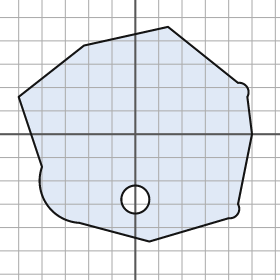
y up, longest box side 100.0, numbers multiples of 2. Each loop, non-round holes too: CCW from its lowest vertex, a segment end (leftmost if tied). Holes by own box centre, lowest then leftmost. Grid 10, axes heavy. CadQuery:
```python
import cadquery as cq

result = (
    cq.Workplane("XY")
    .moveTo(6.0, -46.0)
    .lineTo(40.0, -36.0)
    .threePointArc((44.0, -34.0), (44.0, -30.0))
    .lineTo(50.0, 0.0)
    .lineTo(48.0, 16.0)
    .threePointArc((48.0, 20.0), (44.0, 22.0))
    .lineTo(14.0, 46.0)
    .lineTo(-22.0, 38.0)
    .lineTo(-50.0, 16.0)
    .lineTo(-40.0, -14.0)
    .threePointArc((-38.0, -30.0), (-24.0, -38.0))
    .close()
    .moveTo(0.0, -28.0)
    .circle(6.0)
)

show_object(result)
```